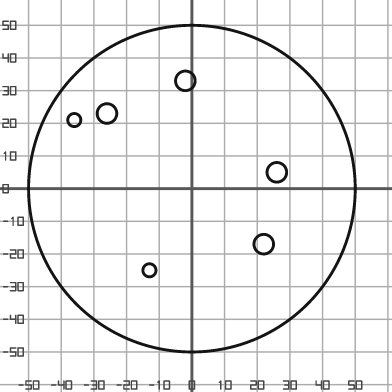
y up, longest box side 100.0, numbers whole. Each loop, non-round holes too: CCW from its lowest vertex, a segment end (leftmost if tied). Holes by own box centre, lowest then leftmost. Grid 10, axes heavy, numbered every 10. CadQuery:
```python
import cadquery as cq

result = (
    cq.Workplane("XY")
    .moveTo(0.0, 0.0)
    .circle(50.0)
    .moveTo(-13.0, -25.0)
    .circle(2.0)
    .moveTo(22.0, -17.0)
    .circle(3.0)
    .moveTo(26.0, 5.0)
    .circle(3.0)
    .moveTo(-36.0, 21.0)
    .circle(2.0)
    .moveTo(-26.0, 23.0)
    .circle(3.0)
    .moveTo(-2.0, 33.0)
    .circle(3.0)
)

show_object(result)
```